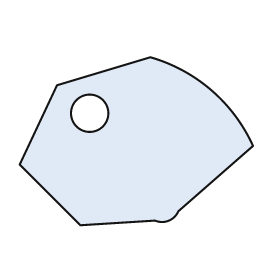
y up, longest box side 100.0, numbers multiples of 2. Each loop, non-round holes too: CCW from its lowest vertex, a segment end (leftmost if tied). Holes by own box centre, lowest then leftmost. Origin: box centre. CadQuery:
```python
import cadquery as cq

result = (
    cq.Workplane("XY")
    .moveTo(-24.0, -36.0)
    .lineTo(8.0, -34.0)
    .threePointArc((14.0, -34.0), (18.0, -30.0))
    .lineTo(50.0, -2.0)
    .threePointArc((32.0, 22.0), (6.0, 36.0))
    .lineTo(-34.0, 24.0)
    .lineTo(-50.0, -10.0)
    .close()
    .moveTo(-20.0, 12.0)
    .circle(8.0)
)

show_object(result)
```